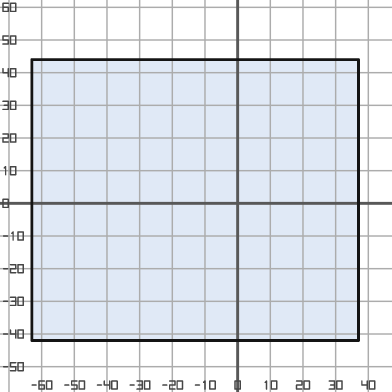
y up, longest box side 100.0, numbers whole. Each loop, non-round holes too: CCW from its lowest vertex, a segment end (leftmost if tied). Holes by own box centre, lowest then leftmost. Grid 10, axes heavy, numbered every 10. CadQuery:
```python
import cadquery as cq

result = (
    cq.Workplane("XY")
    .moveTo(-63.0, -42.0)
    .lineTo(37.0, -42.0)
    .lineTo(37.0, 44.0)
    .lineTo(-63.0, 44.0)
    .close()
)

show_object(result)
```